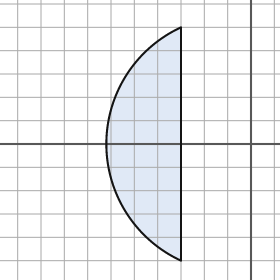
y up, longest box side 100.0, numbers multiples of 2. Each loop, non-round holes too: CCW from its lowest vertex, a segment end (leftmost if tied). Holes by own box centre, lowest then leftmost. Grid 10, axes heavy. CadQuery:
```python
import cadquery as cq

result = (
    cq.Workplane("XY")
    .moveTo(-30.0, -50.0)
    .lineTo(-30.0, 50.0)
    .threePointArc((-62.0, 0.0), (-30.0, -50.0))
    .close()
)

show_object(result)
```